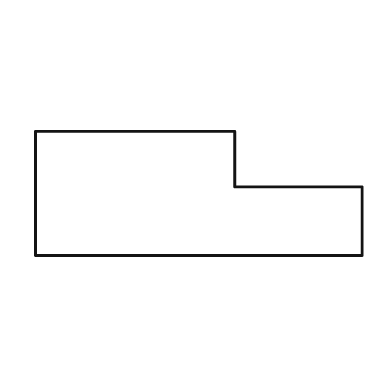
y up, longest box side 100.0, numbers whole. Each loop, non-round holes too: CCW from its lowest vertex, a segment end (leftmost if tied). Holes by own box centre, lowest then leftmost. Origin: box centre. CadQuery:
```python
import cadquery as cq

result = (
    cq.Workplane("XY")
    .moveTo(-50.0, -19.0)
    .lineTo(50.0, -19.0)
    .lineTo(50.0, 2.0)
    .lineTo(11.0, 2.0)
    .lineTo(11.0, 19.0)
    .lineTo(-50.0, 19.0)
    .close()
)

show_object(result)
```